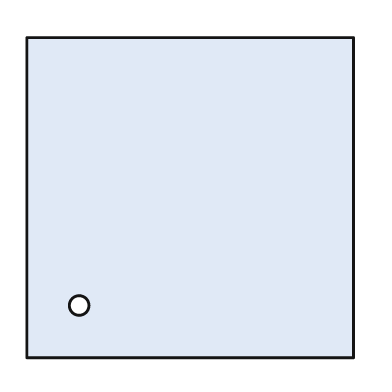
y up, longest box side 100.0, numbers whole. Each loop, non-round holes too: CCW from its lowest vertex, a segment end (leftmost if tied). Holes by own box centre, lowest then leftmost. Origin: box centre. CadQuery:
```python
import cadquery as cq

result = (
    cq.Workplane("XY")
    .moveTo(-50.0, -49.0)
    .lineTo(50.0, -49.0)
    .lineTo(50.0, 49.0)
    .lineTo(-50.0, 49.0)
    .close()
    .moveTo(-34.0, -33.0)
    .circle(3.0)
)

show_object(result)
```